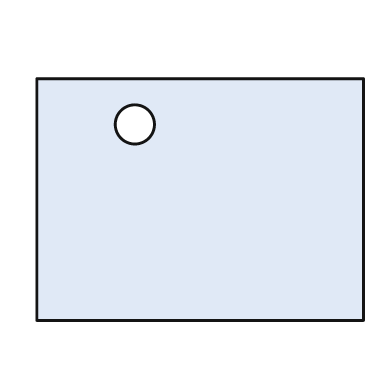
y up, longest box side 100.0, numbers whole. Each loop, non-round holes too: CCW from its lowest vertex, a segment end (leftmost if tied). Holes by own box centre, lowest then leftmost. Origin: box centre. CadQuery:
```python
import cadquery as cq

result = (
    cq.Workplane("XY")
    .moveTo(-50.0, -37.0)
    .lineTo(50.0, -37.0)
    .lineTo(50.0, 37.0)
    .lineTo(-50.0, 37.0)
    .close()
    .moveTo(-20.0, 23.0)
    .circle(6.0)
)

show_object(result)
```